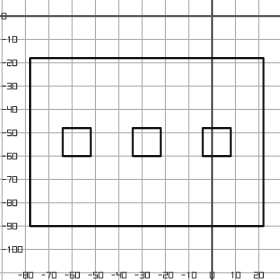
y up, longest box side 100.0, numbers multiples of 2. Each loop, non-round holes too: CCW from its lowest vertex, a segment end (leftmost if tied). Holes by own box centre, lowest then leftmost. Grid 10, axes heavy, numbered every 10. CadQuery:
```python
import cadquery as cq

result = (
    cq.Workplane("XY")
    .moveTo(-78.0, -90.0)
    .lineTo(22.0, -90.0)
    .lineTo(22.0, -18.0)
    .lineTo(-78.0, -18.0)
    .close()
    .moveTo(-64.0, -60.0)
    .lineTo(-52.0, -60.0)
    .lineTo(-52.0, -48.0)
    .lineTo(-64.0, -48.0)
    .close()
    .moveTo(-34.0, -60.0)
    .lineTo(-22.0, -60.0)
    .lineTo(-22.0, -48.0)
    .lineTo(-34.0, -48.0)
    .close()
    .moveTo(-4.0, -60.0)
    .lineTo(8.0, -60.0)
    .lineTo(8.0, -48.0)
    .lineTo(-4.0, -48.0)
    .close()
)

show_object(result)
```